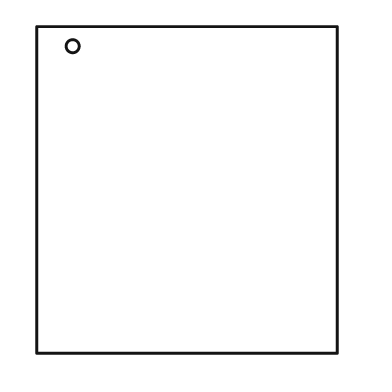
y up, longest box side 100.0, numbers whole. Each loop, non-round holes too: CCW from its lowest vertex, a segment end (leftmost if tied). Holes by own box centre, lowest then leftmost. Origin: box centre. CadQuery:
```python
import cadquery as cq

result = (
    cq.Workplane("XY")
    .moveTo(-46.0, -50.0)
    .lineTo(46.0, -50.0)
    .lineTo(46.0, 50.0)
    .lineTo(-46.0, 50.0)
    .close()
    .moveTo(-35.0, 44.0)
    .circle(2.0)
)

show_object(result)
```